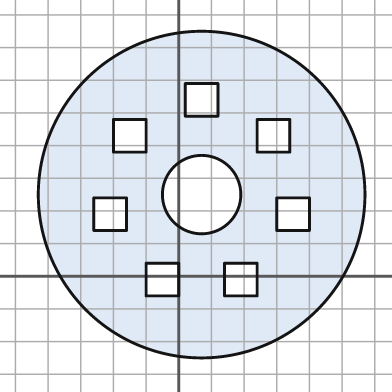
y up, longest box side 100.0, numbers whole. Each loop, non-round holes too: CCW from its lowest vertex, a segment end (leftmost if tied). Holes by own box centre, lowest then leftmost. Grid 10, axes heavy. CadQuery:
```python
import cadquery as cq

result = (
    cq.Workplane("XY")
    .moveTo(7.0, 25.0)
    .circle(50.0)
    .moveTo(-10.0, -6.0)
    .lineTo(0.0, -6.0)
    .lineTo(0.0, 4.0)
    .lineTo(-10.0, 4.0)
    .close()
    .moveTo(14.0, -6.0)
    .lineTo(24.0, -6.0)
    .lineTo(24.0, 4.0)
    .lineTo(14.0, 4.0)
    .close()
    .moveTo(-26.0, 14.0)
    .lineTo(-16.0, 14.0)
    .lineTo(-16.0, 24.0)
    .lineTo(-26.0, 24.0)
    .close()
    .moveTo(30.0, 14.0)
    .lineTo(40.0, 14.0)
    .lineTo(40.0, 24.0)
    .lineTo(30.0, 24.0)
    .close()
    .moveTo(7.0, 25.0)
    .circle(12.0)
    .moveTo(-20.0, 38.0)
    .lineTo(-10.0, 38.0)
    .lineTo(-10.0, 48.0)
    .lineTo(-20.0, 48.0)
    .close()
    .moveTo(24.0, 38.0)
    .lineTo(34.0, 38.0)
    .lineTo(34.0, 48.0)
    .lineTo(24.0, 48.0)
    .close()
    .moveTo(2.0, 49.0)
    .lineTo(12.0, 49.0)
    .lineTo(12.0, 59.0)
    .lineTo(2.0, 59.0)
    .close()
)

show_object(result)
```